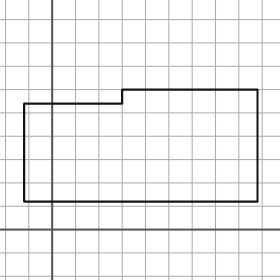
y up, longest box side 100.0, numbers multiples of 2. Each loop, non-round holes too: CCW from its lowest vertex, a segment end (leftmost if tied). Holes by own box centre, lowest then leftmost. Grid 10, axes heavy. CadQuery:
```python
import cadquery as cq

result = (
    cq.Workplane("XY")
    .moveTo(-12.0, 12.0)
    .lineTo(88.0, 12.0)
    .lineTo(88.0, 60.0)
    .lineTo(30.0, 60.0)
    .lineTo(30.0, 54.0)
    .lineTo(-12.0, 54.0)
    .close()
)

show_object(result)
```